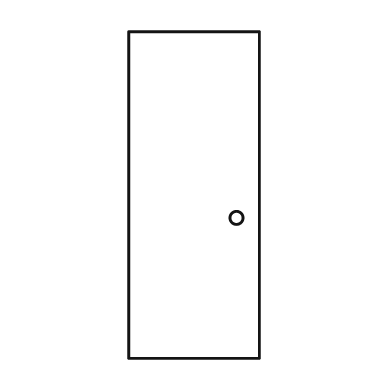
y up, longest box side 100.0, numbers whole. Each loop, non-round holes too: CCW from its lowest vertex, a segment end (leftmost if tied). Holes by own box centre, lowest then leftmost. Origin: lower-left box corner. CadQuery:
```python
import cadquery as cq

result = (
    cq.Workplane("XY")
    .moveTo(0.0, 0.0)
    .lineTo(40.0, 0.0)
    .lineTo(40.0, 100.0)
    .lineTo(0.0, 100.0)
    .close()
    .moveTo(33.0, 43.0)
    .circle(2.0)
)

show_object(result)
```